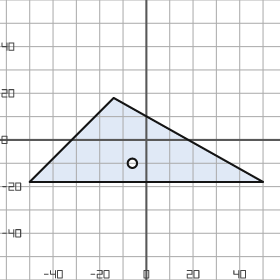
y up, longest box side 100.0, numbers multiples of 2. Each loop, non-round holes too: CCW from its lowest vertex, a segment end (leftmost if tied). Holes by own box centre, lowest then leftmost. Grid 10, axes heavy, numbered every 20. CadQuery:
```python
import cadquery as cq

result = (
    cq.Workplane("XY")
    .moveTo(-50.0, -18.0)
    .lineTo(50.0, -18.0)
    .lineTo(-14.0, 18.0)
    .close()
    .moveTo(-6.0, -10.0)
    .circle(2.0)
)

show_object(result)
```